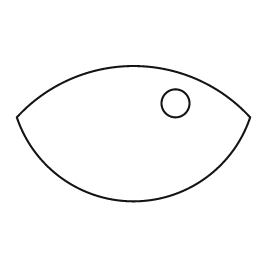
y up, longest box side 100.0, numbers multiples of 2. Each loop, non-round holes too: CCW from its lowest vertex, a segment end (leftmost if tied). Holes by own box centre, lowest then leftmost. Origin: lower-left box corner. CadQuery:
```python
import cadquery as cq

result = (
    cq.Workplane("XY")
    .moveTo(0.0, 36.0)
    .threePointArc((50.0, 0.0), (100.0, 36.0))
    .threePointArc((50.0, 58.0), (0.0, 36.0))
    .close()
    .moveTo(68.0, 42.0)
    .circle(6.0)
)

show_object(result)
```